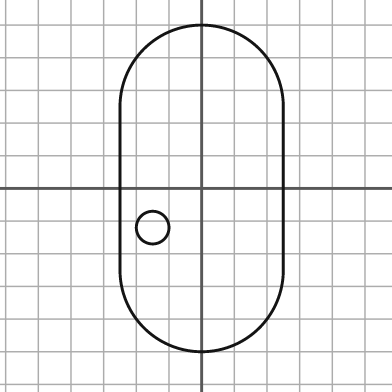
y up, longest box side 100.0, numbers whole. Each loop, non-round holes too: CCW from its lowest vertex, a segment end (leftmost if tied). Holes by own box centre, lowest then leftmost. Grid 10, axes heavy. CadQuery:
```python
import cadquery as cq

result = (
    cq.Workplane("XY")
    .moveTo(-25.0, -25.0)
    .threePointArc((0.0, -50.0), (25.0, -25.0))
    .lineTo(25.0, 25.0)
    .threePointArc((0.0, 50.0), (-25.0, 25.0))
    .close()
    .moveTo(-15.0, -12.0)
    .circle(5.0)
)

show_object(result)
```